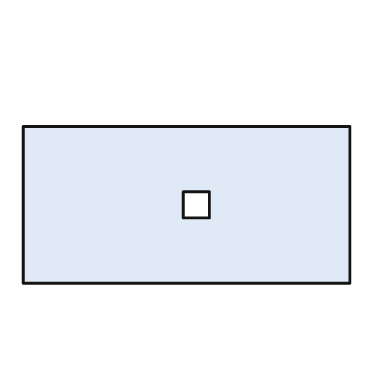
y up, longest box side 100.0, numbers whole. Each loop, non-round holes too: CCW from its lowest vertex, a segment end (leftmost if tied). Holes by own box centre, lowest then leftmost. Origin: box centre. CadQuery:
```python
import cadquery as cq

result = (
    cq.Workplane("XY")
    .moveTo(-50.0, -24.0)
    .lineTo(50.0, -24.0)
    .lineTo(50.0, 24.0)
    .lineTo(-50.0, 24.0)
    .close()
    .moveTo(-1.0, -4.0)
    .lineTo(7.0, -4.0)
    .lineTo(7.0, 4.0)
    .lineTo(-1.0, 4.0)
    .close()
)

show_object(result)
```